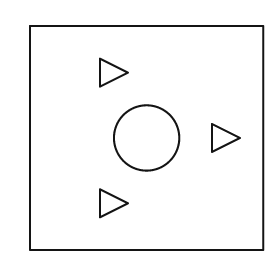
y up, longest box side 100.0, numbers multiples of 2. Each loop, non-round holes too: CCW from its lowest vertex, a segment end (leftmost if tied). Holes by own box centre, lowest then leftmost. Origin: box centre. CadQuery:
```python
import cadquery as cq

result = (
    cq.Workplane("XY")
    .moveTo(-50.0, -48.0)
    .lineTo(50.0, -48.0)
    .lineTo(50.0, 48.0)
    .lineTo(-50.0, 48.0)
    .close()
    .moveTo(-20.0, -34.0)
    .lineTo(-8.0, -28.0)
    .lineTo(-20.0, -22.0)
    .close()
    .moveTo(0.0, 0.0)
    .circle(14.0)
    .moveTo(28.0, -6.0)
    .lineTo(40.0, 0.0)
    .lineTo(28.0, 6.0)
    .close()
    .moveTo(-20.0, 22.0)
    .lineTo(-8.0, 28.0)
    .lineTo(-20.0, 34.0)
    .close()
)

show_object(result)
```